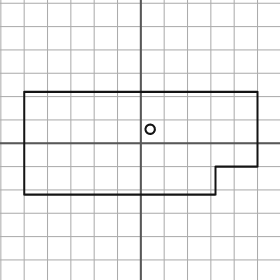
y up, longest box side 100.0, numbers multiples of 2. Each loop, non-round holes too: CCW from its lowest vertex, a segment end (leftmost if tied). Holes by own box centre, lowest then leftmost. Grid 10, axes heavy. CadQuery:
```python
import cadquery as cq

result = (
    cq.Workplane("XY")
    .moveTo(-50.0, -22.0)
    .lineTo(32.0, -22.0)
    .lineTo(32.0, -10.0)
    .lineTo(50.0, -10.0)
    .lineTo(50.0, 22.0)
    .lineTo(-50.0, 22.0)
    .close()
    .moveTo(4.0, 6.0)
    .circle(2.0)
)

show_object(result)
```